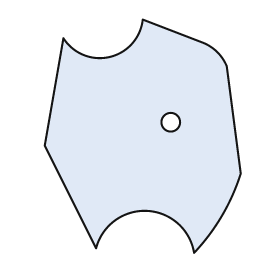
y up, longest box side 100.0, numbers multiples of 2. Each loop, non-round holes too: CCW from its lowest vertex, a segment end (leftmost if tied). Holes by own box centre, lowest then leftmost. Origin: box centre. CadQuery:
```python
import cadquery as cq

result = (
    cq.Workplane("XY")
    .moveTo(22.0, -50.0)
    .threePointArc((34.0, -34.0), (42.0, -16.0))
    .lineTo(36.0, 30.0)
    .threePointArc((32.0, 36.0), (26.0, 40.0))
    .lineTo(0.0, 50.0)
    .threePointArc((-14.0, 34.0), (-34.0, 42.0))
    .lineTo(-42.0, -4.0)
    .lineTo(-20.0, -48.0)
    .threePointArc((2.0, -32.0), (22.0, -50.0))
    .close()
    .moveTo(12.0, 6.0)
    .circle(4.0)
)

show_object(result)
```